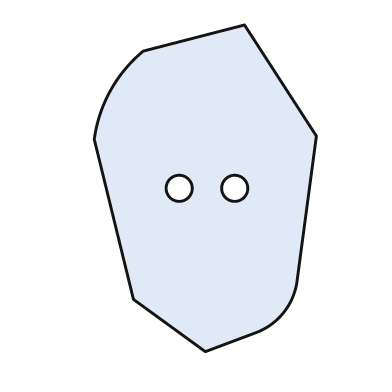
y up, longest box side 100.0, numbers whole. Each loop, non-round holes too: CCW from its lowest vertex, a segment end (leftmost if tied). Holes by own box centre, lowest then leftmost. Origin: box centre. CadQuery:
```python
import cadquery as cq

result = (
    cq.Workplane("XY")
    .moveTo(0.0, -50.0)
    .lineTo(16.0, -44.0)
    .threePointArc((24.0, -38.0), (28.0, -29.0))
    .lineTo(34.0, 16.0)
    .lineTo(12.0, 50.0)
    .lineTo(-19.0, 42.0)
    .threePointArc((-29.0, 30.0), (-34.0, 15.0))
    .lineTo(-22.0, -34.0)
    .close()
    .moveTo(-8.0, 0.0)
    .circle(4.0)
    .moveTo(9.0, 0.0)
    .circle(4.0)
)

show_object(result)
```